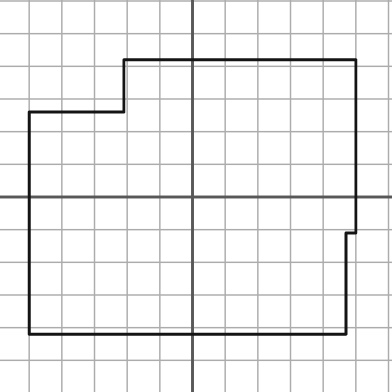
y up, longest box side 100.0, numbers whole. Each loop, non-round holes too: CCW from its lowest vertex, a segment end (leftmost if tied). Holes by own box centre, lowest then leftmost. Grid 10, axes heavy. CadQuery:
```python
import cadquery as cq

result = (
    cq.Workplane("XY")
    .moveTo(-50.0, -42.0)
    .lineTo(47.0, -42.0)
    .lineTo(47.0, -11.0)
    .lineTo(50.0, -11.0)
    .lineTo(50.0, 42.0)
    .lineTo(-21.0, 42.0)
    .lineTo(-21.0, 26.0)
    .lineTo(-50.0, 26.0)
    .close()
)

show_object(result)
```